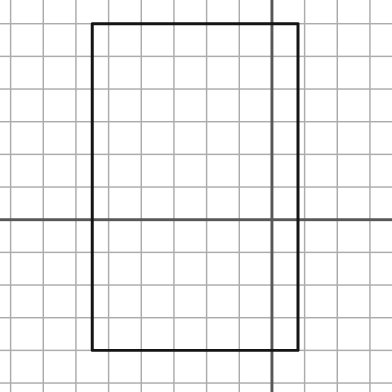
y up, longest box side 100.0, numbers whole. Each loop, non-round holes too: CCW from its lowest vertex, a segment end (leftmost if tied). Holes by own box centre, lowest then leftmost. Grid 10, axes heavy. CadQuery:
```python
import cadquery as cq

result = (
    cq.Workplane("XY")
    .moveTo(-55.0, -40.0)
    .lineTo(8.0, -40.0)
    .lineTo(8.0, 60.0)
    .lineTo(-55.0, 60.0)
    .close()
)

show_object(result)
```